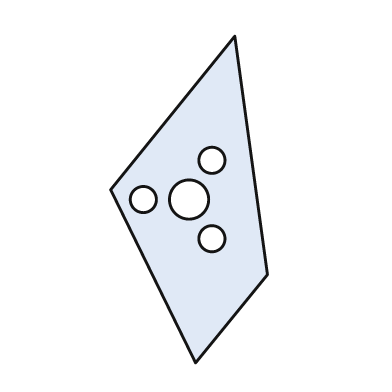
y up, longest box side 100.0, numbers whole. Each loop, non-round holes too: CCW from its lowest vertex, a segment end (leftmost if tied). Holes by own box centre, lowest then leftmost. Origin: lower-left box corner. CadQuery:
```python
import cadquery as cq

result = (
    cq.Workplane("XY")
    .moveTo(26.0, 0.0)
    .lineTo(48.0, 27.0)
    .lineTo(38.0, 100.0)
    .lineTo(0.0, 53.0)
    .close()
    .moveTo(31.0, 38.0)
    .circle(4.0)
    .moveTo(10.0, 50.0)
    .circle(4.0)
    .moveTo(24.0, 50.0)
    .circle(6.0)
    .moveTo(31.0, 62.0)
    .circle(4.0)
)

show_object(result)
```